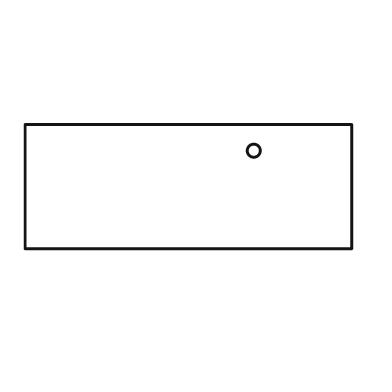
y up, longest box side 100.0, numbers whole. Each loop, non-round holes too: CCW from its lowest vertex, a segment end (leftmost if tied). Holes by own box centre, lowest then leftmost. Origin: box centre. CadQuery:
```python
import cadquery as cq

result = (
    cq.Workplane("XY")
    .moveTo(-50.0, -19.0)
    .lineTo(50.0, -19.0)
    .lineTo(50.0, 19.0)
    .lineTo(-50.0, 19.0)
    .close()
    .moveTo(20.0, 11.0)
    .circle(2.0)
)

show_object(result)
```